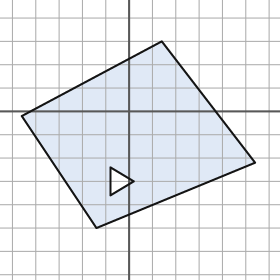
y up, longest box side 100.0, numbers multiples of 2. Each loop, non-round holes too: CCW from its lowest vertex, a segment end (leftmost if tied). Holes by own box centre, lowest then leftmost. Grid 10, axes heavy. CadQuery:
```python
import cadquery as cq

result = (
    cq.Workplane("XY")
    .moveTo(-14.0, -50.0)
    .lineTo(54.0, -22.0)
    .lineTo(14.0, 30.0)
    .lineTo(-46.0, -2.0)
    .close()
    .moveTo(-8.0, -36.0)
    .lineTo(2.0, -30.0)
    .lineTo(-8.0, -24.0)
    .close()
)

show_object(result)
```